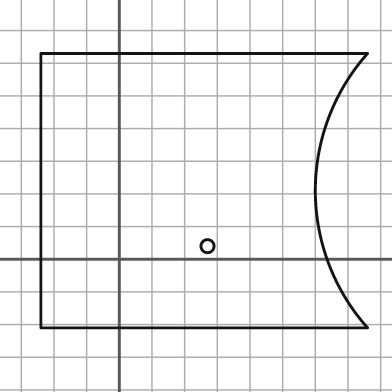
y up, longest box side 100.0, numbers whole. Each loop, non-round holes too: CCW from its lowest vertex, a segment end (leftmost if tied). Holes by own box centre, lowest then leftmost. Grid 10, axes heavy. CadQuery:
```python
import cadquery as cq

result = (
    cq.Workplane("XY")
    .moveTo(-24.0, -21.0)
    .lineTo(76.0, -21.0)
    .threePointArc((60.0, 21.0), (76.0, 63.0))
    .lineTo(-24.0, 63.0)
    .close()
    .moveTo(27.0, 4.0)
    .circle(2.0)
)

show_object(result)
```